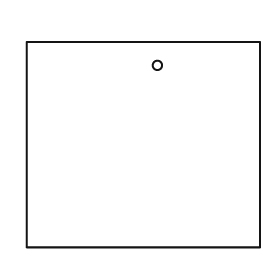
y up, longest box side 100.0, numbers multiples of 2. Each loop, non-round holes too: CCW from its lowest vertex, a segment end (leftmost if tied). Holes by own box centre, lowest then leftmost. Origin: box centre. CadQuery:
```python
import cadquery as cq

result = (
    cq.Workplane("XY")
    .moveTo(-50.0, -44.0)
    .lineTo(50.0, -44.0)
    .lineTo(50.0, 44.0)
    .lineTo(-50.0, 44.0)
    .close()
    .moveTo(6.0, 34.0)
    .circle(2.0)
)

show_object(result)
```